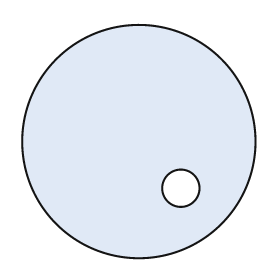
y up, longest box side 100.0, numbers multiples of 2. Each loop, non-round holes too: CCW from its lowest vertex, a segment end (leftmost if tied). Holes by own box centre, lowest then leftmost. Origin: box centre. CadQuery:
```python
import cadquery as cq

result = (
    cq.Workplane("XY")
    .moveTo(0.0, 0.0)
    .circle(50.0)
    .moveTo(18.0, -20.0)
    .circle(8.0)
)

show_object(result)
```